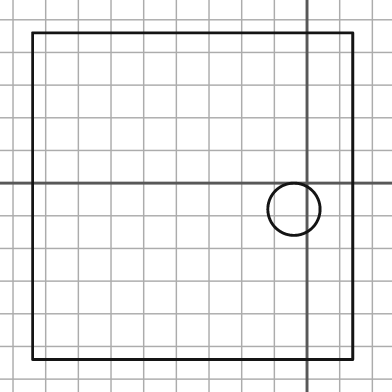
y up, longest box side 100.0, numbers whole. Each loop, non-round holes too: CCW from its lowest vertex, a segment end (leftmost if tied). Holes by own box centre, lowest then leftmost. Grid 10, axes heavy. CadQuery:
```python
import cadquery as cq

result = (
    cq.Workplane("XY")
    .moveTo(-84.0, -54.0)
    .lineTo(14.0, -54.0)
    .lineTo(14.0, 46.0)
    .lineTo(-84.0, 46.0)
    .close()
    .moveTo(-4.0, -8.0)
    .circle(8.0)
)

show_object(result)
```